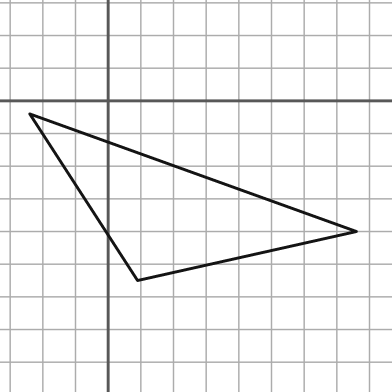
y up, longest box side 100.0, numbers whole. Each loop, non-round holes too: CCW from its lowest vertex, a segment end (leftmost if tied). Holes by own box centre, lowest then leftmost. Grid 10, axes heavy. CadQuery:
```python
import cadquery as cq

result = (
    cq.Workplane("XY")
    .moveTo(9.0, -55.0)
    .lineTo(76.0, -40.0)
    .lineTo(-24.0, -4.0)
    .close()
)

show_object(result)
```